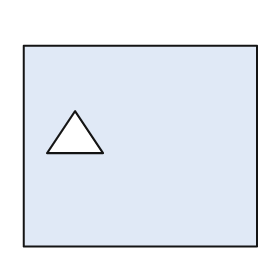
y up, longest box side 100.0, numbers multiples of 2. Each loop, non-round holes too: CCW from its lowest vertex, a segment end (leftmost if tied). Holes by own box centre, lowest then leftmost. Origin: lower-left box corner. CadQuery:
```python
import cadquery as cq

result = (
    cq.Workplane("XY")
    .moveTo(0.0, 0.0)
    .lineTo(100.0, 0.0)
    .lineTo(100.0, 86.0)
    .lineTo(0.0, 86.0)
    .close()
    .moveTo(10.0, 40.0)
    .lineTo(34.0, 40.0)
    .lineTo(22.0, 58.0)
    .close()
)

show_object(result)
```